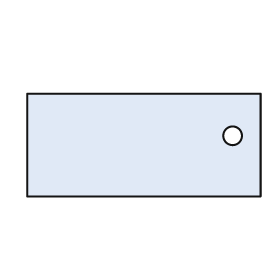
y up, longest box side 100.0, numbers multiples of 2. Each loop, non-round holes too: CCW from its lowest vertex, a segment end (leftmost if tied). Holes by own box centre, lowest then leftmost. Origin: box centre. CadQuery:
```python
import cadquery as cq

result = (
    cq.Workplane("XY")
    .moveTo(-50.0, -22.0)
    .lineTo(50.0, -22.0)
    .lineTo(50.0, 22.0)
    .lineTo(-50.0, 22.0)
    .close()
    .moveTo(38.0, 4.0)
    .circle(4.0)
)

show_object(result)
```